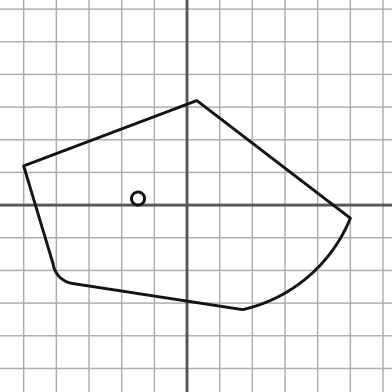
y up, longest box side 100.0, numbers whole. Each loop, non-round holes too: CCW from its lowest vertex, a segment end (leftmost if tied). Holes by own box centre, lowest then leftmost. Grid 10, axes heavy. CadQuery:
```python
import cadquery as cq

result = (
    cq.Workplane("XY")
    .moveTo(17.0, -32.0)
    .threePointArc((37.0, -22.0), (50.0, -4.0))
    .lineTo(3.0, 32.0)
    .lineTo(-50.0, 12.0)
    .lineTo(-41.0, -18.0)
    .threePointArc((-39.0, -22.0), (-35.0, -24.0))
    .close()
    .moveTo(-15.0, 2.0)
    .circle(2.0)
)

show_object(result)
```